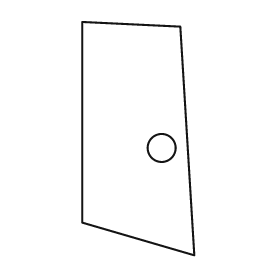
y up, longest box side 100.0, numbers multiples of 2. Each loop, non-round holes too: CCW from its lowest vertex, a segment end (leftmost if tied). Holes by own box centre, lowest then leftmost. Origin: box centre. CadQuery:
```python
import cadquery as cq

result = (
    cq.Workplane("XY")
    .moveTo(24.0, -50.0)
    .lineTo(18.0, 48.0)
    .lineTo(-24.0, 50.0)
    .lineTo(-24.0, -36.0)
    .close()
    .moveTo(10.0, -4.0)
    .circle(6.0)
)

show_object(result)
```